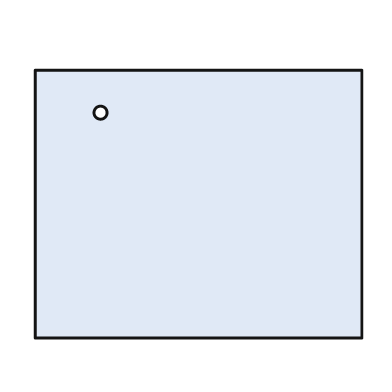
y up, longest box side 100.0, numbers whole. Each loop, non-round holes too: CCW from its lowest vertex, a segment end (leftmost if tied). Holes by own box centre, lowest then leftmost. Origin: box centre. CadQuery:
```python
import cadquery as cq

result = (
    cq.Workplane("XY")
    .moveTo(-50.0, -41.0)
    .lineTo(50.0, -41.0)
    .lineTo(50.0, 41.0)
    .lineTo(-50.0, 41.0)
    .close()
    .moveTo(-30.0, 28.0)
    .circle(2.0)
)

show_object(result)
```